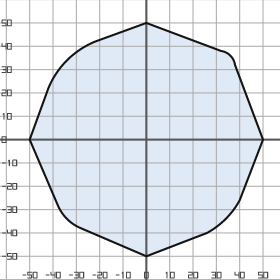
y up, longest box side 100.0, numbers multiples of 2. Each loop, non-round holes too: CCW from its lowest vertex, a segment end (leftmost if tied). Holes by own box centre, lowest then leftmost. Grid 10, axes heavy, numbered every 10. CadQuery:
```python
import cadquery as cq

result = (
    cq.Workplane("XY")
    .moveTo(0.0, -50.0)
    .lineTo(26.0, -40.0)
    .threePointArc((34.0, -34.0), (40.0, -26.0))
    .lineTo(50.0, 0.0)
    .lineTo(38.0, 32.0)
    .threePointArc((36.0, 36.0), (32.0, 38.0))
    .lineTo(0.0, 50.0)
    .lineTo(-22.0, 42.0)
    .threePointArc((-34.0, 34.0), (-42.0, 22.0))
    .lineTo(-50.0, 0.0)
    .lineTo(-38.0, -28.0)
    .threePointArc((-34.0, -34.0), (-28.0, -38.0))
    .close()
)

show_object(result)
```